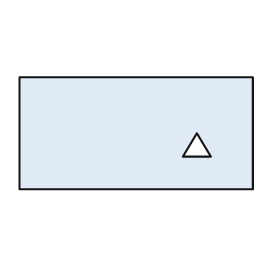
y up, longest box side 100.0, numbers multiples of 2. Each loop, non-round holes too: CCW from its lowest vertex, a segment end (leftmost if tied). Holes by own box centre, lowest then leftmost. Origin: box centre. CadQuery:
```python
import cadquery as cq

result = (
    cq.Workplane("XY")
    .moveTo(-50.0, -24.0)
    .lineTo(50.0, -24.0)
    .lineTo(50.0, 24.0)
    .lineTo(-50.0, 24.0)
    .close()
    .moveTo(20.0, -10.0)
    .lineTo(32.0, -10.0)
    .lineTo(26.0, 0.0)
    .close()
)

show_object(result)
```